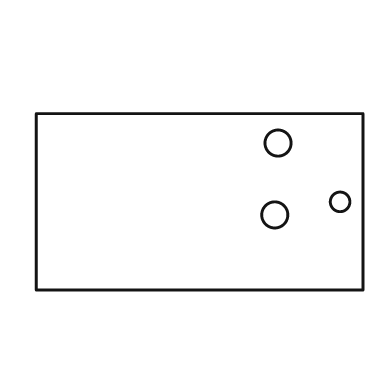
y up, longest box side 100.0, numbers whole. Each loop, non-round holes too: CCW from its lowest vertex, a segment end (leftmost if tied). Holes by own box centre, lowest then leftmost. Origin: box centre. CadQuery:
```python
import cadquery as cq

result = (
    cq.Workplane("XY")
    .moveTo(-50.0, -27.0)
    .lineTo(50.0, -27.0)
    .lineTo(50.0, 27.0)
    .lineTo(-50.0, 27.0)
    .close()
    .moveTo(23.0, -4.0)
    .circle(4.0)
    .moveTo(43.0, 0.0)
    .circle(3.0)
    .moveTo(24.0, 18.0)
    .circle(4.0)
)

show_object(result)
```